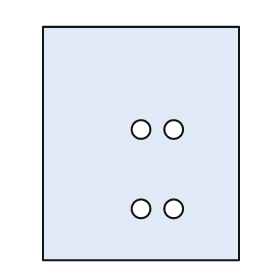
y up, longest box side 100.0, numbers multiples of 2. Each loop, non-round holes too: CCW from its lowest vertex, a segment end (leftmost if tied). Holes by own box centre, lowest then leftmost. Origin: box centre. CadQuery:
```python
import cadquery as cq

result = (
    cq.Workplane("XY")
    .moveTo(-42.0, -50.0)
    .lineTo(42.0, -50.0)
    .lineTo(42.0, 50.0)
    .lineTo(-42.0, 50.0)
    .close()
    .moveTo(0.0, -28.0)
    .circle(4.0)
    .moveTo(14.0, -28.0)
    .circle(4.0)
    .moveTo(0.0, 6.0)
    .circle(4.0)
    .moveTo(14.0, 6.0)
    .circle(4.0)
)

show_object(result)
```